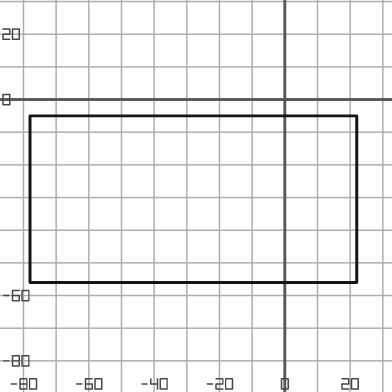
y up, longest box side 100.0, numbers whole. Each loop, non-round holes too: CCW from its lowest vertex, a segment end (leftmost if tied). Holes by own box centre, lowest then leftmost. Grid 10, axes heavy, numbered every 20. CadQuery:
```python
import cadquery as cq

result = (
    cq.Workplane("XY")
    .moveTo(-78.0, -56.0)
    .lineTo(22.0, -56.0)
    .lineTo(22.0, -5.0)
    .lineTo(-78.0, -5.0)
    .close()
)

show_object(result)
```